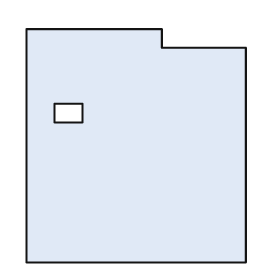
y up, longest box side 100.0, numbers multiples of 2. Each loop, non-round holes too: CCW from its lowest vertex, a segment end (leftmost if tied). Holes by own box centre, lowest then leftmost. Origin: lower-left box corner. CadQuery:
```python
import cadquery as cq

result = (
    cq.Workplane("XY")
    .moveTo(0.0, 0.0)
    .lineTo(94.0, 0.0)
    .lineTo(94.0, 92.0)
    .lineTo(58.0, 92.0)
    .lineTo(58.0, 100.0)
    .lineTo(0.0, 100.0)
    .close()
    .moveTo(12.0, 60.0)
    .lineTo(24.0, 60.0)
    .lineTo(24.0, 68.0)
    .lineTo(12.0, 68.0)
    .close()
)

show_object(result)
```